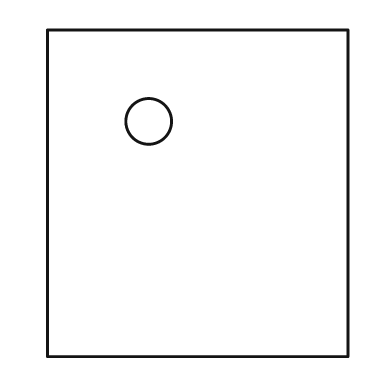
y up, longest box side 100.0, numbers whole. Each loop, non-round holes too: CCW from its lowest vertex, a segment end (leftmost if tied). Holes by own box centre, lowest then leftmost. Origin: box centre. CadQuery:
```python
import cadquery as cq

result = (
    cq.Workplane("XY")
    .moveTo(-46.0, -50.0)
    .lineTo(46.0, -50.0)
    .lineTo(46.0, 50.0)
    .lineTo(-46.0, 50.0)
    .close()
    .moveTo(-15.0, 22.0)
    .circle(7.0)
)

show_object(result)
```